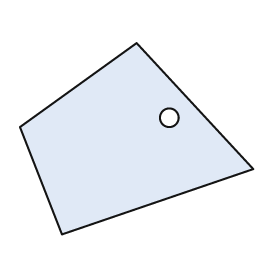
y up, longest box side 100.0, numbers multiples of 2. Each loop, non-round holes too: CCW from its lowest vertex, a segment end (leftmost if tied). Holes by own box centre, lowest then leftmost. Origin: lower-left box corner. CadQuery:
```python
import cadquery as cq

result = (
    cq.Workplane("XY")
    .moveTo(18.0, 0.0)
    .lineTo(100.0, 28.0)
    .lineTo(50.0, 82.0)
    .lineTo(0.0, 46.0)
    .close()
    .moveTo(64.0, 50.0)
    .circle(4.0)
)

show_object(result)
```